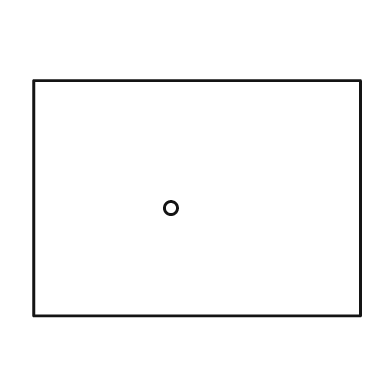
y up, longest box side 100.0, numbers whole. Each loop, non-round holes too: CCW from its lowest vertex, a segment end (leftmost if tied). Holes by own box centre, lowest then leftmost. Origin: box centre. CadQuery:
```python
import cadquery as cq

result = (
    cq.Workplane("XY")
    .moveTo(-50.0, -36.0)
    .lineTo(50.0, -36.0)
    .lineTo(50.0, 36.0)
    .lineTo(-50.0, 36.0)
    .close()
    .moveTo(-8.0, -3.0)
    .circle(2.0)
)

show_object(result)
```